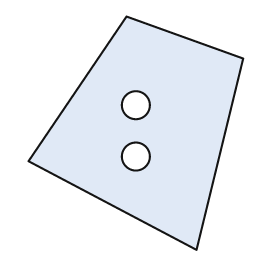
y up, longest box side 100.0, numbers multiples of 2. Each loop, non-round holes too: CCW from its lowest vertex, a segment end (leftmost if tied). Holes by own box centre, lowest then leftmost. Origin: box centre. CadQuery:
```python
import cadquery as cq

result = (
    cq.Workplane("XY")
    .moveTo(26.0, -50.0)
    .lineTo(46.0, 32.0)
    .lineTo(-4.0, 50.0)
    .lineTo(-46.0, -12.0)
    .close()
    .moveTo(0.0, -10.0)
    .circle(6.0)
    .moveTo(0.0, 12.0)
    .circle(6.0)
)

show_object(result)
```